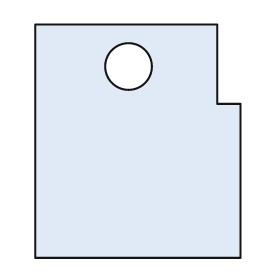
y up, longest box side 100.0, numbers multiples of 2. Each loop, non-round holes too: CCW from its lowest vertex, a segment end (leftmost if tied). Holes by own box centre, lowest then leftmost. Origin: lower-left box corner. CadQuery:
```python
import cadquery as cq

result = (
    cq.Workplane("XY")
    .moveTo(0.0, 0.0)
    .lineTo(88.0, 0.0)
    .lineTo(88.0, 66.0)
    .lineTo(78.0, 66.0)
    .lineTo(78.0, 100.0)
    .lineTo(0.0, 100.0)
    .close()
    .moveTo(40.0, 82.0)
    .circle(10.0)
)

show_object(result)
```